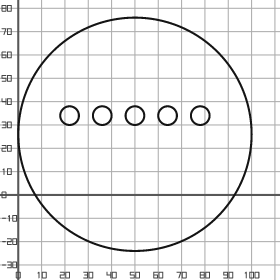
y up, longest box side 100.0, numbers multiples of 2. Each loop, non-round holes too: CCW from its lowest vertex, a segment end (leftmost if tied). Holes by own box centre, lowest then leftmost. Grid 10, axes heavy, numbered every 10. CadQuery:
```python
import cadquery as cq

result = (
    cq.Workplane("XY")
    .moveTo(50.0, 26.0)
    .circle(50.0)
    .moveTo(22.0, 34.0)
    .circle(4.0)
    .moveTo(36.0, 34.0)
    .circle(4.0)
    .moveTo(50.0, 34.0)
    .circle(4.0)
    .moveTo(64.0, 34.0)
    .circle(4.0)
    .moveTo(78.0, 34.0)
    .circle(4.0)
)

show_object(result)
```